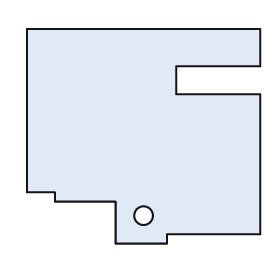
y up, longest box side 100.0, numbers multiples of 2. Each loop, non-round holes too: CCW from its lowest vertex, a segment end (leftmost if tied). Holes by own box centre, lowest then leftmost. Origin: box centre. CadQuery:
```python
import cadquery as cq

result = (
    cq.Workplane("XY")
    .moveTo(-12.0, -46.0)
    .lineTo(10.0, -46.0)
    .lineTo(10.0, -42.0)
    .lineTo(50.0, -42.0)
    .lineTo(50.0, 18.0)
    .lineTo(14.0, 18.0)
    .lineTo(14.0, 30.0)
    .lineTo(50.0, 30.0)
    .lineTo(50.0, 46.0)
    .lineTo(-50.0, 46.0)
    .lineTo(-50.0, -24.0)
    .lineTo(-38.0, -24.0)
    .lineTo(-38.0, -28.0)
    .lineTo(-12.0, -28.0)
    .close()
    .moveTo(0.0, -34.0)
    .circle(4.0)
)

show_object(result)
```